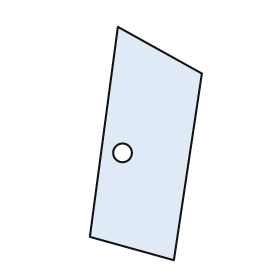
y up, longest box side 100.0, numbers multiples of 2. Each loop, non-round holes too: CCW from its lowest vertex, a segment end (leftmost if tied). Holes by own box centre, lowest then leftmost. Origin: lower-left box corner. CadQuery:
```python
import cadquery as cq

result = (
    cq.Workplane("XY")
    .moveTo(36.0, 0.0)
    .lineTo(48.0, 80.0)
    .lineTo(12.0, 100.0)
    .lineTo(0.0, 10.0)
    .close()
    .moveTo(14.0, 46.0)
    .circle(4.0)
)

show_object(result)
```